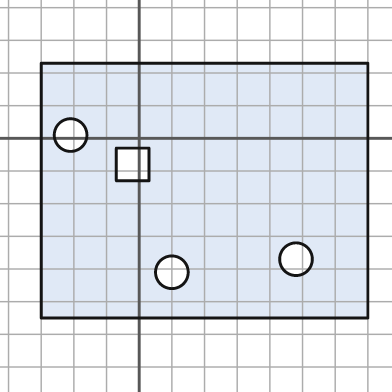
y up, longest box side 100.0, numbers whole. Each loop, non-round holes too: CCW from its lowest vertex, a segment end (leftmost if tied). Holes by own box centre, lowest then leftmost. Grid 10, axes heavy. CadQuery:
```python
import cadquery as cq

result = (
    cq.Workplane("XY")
    .moveTo(-30.0, -55.0)
    .lineTo(70.0, -55.0)
    .lineTo(70.0, 23.0)
    .lineTo(-30.0, 23.0)
    .close()
    .moveTo(10.0, -41.0)
    .circle(5.0)
    .moveTo(48.0, -37.0)
    .circle(5.0)
    .moveTo(-7.0, -13.0)
    .lineTo(3.0, -13.0)
    .lineTo(3.0, -3.0)
    .lineTo(-7.0, -3.0)
    .close()
    .moveTo(-21.0, 1.0)
    .circle(5.0)
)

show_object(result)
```